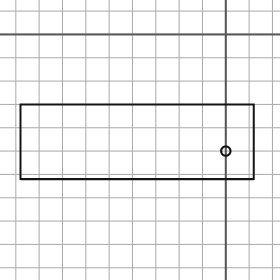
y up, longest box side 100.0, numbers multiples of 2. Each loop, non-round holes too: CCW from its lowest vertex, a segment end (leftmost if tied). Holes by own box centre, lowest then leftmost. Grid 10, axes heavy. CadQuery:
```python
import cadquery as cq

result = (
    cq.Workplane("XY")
    .moveTo(-88.0, -62.0)
    .lineTo(12.0, -62.0)
    .lineTo(12.0, -30.0)
    .lineTo(-88.0, -30.0)
    .close()
    .moveTo(0.0, -50.0)
    .circle(2.0)
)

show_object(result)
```